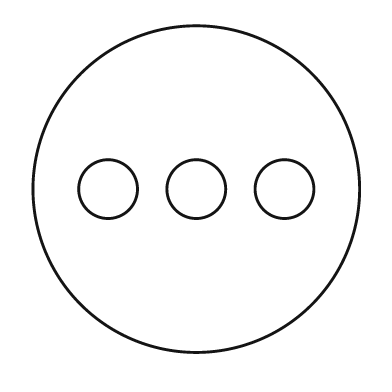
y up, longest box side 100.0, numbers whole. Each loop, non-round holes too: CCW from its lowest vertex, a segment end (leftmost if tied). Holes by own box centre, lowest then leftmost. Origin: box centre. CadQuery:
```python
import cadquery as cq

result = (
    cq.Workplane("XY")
    .moveTo(0.0, 0.0)
    .circle(50.0)
    .moveTo(-27.0, 0.0)
    .circle(9.0)
    .moveTo(0.0, 0.0)
    .circle(9.0)
    .moveTo(27.0, 0.0)
    .circle(9.0)
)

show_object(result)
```